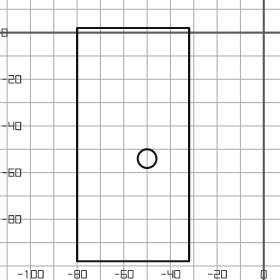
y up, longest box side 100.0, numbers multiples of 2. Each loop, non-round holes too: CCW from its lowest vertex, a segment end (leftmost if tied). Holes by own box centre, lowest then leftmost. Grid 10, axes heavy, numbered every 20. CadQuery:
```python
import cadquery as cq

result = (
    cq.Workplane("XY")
    .moveTo(-80.0, -98.0)
    .lineTo(-32.0, -98.0)
    .lineTo(-32.0, 2.0)
    .lineTo(-80.0, 2.0)
    .close()
    .moveTo(-50.0, -54.0)
    .circle(4.0)
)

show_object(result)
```